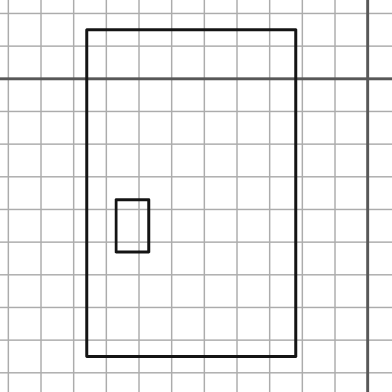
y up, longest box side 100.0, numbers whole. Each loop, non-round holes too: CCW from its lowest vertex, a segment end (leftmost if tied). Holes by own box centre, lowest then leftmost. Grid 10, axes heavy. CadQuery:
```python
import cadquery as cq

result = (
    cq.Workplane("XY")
    .moveTo(-86.0, -85.0)
    .lineTo(-22.0, -85.0)
    .lineTo(-22.0, 15.0)
    .lineTo(-86.0, 15.0)
    .close()
    .moveTo(-77.0, -53.0)
    .lineTo(-67.0, -53.0)
    .lineTo(-67.0, -37.0)
    .lineTo(-77.0, -37.0)
    .close()
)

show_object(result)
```